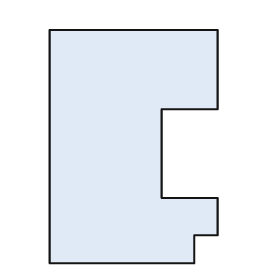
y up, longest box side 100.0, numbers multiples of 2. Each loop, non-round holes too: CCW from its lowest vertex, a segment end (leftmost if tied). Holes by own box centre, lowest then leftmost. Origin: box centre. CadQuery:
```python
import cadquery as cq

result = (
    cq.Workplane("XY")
    .moveTo(-36.0, -50.0)
    .lineTo(26.0, -50.0)
    .lineTo(26.0, -38.0)
    .lineTo(36.0, -38.0)
    .lineTo(36.0, -22.0)
    .lineTo(12.0, -22.0)
    .lineTo(12.0, 16.0)
    .lineTo(36.0, 16.0)
    .lineTo(36.0, 50.0)
    .lineTo(-36.0, 50.0)
    .close()
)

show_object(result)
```